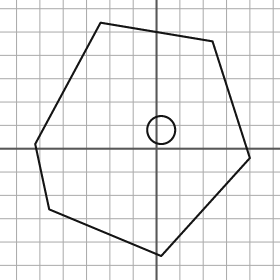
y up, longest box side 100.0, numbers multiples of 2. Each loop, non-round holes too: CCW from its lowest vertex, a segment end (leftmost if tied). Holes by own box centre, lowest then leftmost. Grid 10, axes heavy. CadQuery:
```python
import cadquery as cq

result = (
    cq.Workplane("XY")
    .moveTo(2.0, -46.0)
    .lineTo(40.0, -4.0)
    .lineTo(24.0, 46.0)
    .lineTo(-24.0, 54.0)
    .lineTo(-52.0, 2.0)
    .lineTo(-46.0, -26.0)
    .close()
    .moveTo(2.0, 8.0)
    .circle(6.0)
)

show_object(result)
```